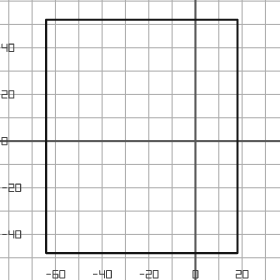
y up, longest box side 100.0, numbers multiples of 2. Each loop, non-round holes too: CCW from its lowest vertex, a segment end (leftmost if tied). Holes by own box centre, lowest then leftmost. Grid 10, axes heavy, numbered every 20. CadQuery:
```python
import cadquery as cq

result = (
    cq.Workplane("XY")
    .moveTo(-64.0, -48.0)
    .lineTo(18.0, -48.0)
    .lineTo(18.0, 52.0)
    .lineTo(-64.0, 52.0)
    .close()
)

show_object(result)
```